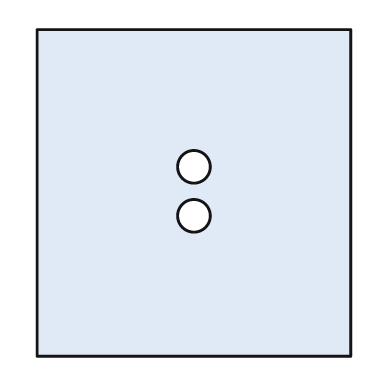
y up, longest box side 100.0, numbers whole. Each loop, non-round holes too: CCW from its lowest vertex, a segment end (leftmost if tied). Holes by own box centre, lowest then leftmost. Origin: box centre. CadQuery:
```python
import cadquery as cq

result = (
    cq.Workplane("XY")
    .moveTo(-48.0, -50.0)
    .lineTo(48.0, -50.0)
    .lineTo(48.0, 50.0)
    .lineTo(-48.0, 50.0)
    .close()
    .moveTo(0.0, -7.0)
    .circle(5.0)
    .moveTo(0.0, 8.0)
    .circle(5.0)
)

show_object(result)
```